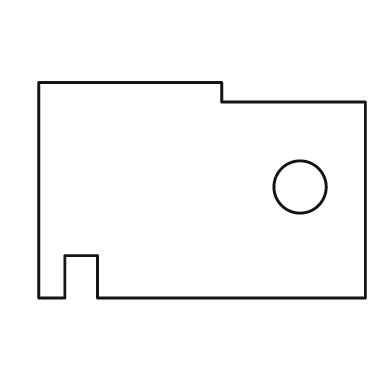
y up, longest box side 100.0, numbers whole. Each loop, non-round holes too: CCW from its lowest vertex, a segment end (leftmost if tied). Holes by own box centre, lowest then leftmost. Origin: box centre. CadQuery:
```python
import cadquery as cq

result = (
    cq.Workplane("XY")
    .moveTo(-50.0, -33.0)
    .lineTo(-42.0, -33.0)
    .lineTo(-42.0, -20.0)
    .lineTo(-32.0, -20.0)
    .lineTo(-32.0, -33.0)
    .lineTo(50.0, -33.0)
    .lineTo(50.0, 27.0)
    .lineTo(6.0, 27.0)
    .lineTo(6.0, 33.0)
    .lineTo(-50.0, 33.0)
    .close()
    .moveTo(30.0, 1.0)
    .circle(8.0)
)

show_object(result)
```